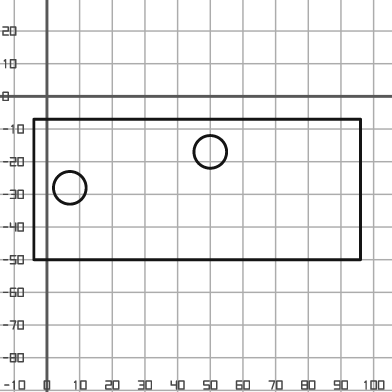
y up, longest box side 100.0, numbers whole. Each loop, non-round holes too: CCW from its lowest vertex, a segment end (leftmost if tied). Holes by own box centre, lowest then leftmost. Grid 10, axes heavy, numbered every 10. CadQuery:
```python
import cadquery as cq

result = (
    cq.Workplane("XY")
    .moveTo(-4.0, -50.0)
    .lineTo(96.0, -50.0)
    .lineTo(96.0, -7.0)
    .lineTo(-4.0, -7.0)
    .close()
    .moveTo(7.0, -28.0)
    .circle(5.0)
    .moveTo(50.0, -17.0)
    .circle(5.0)
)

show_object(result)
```